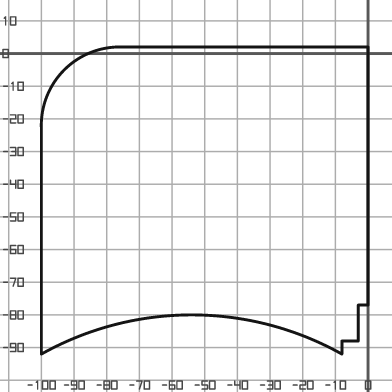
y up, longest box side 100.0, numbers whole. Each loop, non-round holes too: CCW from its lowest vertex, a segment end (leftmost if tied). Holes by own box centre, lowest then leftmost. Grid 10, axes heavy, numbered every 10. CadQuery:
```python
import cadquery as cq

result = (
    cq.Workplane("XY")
    .moveTo(-100.0, -92.0)
    .threePointArc((-54.0, -80.0), (-8.0, -92.0))
    .lineTo(-8.0, -88.0)
    .lineTo(-3.0, -88.0)
    .lineTo(-3.0, -77.0)
    .lineTo(0.0, -77.0)
    .lineTo(0.0, 2.0)
    .lineTo(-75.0, 2.0)
    .threePointArc((-93.0, -5.0), (-100.0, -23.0))
    .close()
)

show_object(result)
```